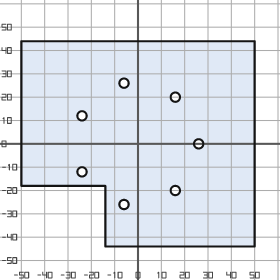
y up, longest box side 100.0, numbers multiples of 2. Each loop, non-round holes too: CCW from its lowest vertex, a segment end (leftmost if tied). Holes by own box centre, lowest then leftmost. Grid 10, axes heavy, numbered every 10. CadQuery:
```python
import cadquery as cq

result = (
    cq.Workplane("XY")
    .moveTo(-14.0, -44.0)
    .lineTo(50.0, -44.0)
    .lineTo(50.0, 44.0)
    .lineTo(-50.0, 44.0)
    .lineTo(-50.0, -18.0)
    .lineTo(-14.0, -18.0)
    .close()
    .moveTo(-6.0, -26.0)
    .circle(2.0)
    .moveTo(16.0, -20.0)
    .circle(2.0)
    .moveTo(-24.0, -12.0)
    .circle(2.0)
    .moveTo(26.0, 0.0)
    .circle(2.0)
    .moveTo(-24.0, 12.0)
    .circle(2.0)
    .moveTo(16.0, 20.0)
    .circle(2.0)
    .moveTo(-6.0, 26.0)
    .circle(2.0)
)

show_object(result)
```